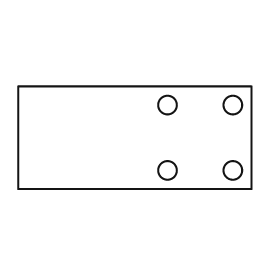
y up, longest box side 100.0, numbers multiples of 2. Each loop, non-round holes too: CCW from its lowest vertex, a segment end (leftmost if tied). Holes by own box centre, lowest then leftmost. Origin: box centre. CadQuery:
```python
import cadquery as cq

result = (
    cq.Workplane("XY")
    .moveTo(-50.0, -22.0)
    .lineTo(50.0, -22.0)
    .lineTo(50.0, 22.0)
    .lineTo(-50.0, 22.0)
    .close()
    .moveTo(14.0, -14.0)
    .circle(4.0)
    .moveTo(42.0, -14.0)
    .circle(4.0)
    .moveTo(14.0, 14.0)
    .circle(4.0)
    .moveTo(42.0, 14.0)
    .circle(4.0)
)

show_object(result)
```